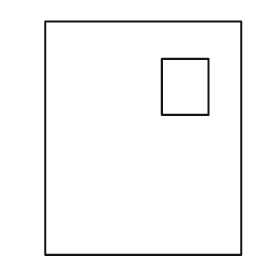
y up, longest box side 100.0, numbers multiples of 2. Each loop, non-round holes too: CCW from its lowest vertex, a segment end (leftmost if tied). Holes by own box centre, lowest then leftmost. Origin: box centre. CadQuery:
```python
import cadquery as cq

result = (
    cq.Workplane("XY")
    .moveTo(-42.0, -50.0)
    .lineTo(42.0, -50.0)
    .lineTo(42.0, 50.0)
    .lineTo(-42.0, 50.0)
    .close()
    .moveTo(8.0, 10.0)
    .lineTo(28.0, 10.0)
    .lineTo(28.0, 34.0)
    .lineTo(8.0, 34.0)
    .close()
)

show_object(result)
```